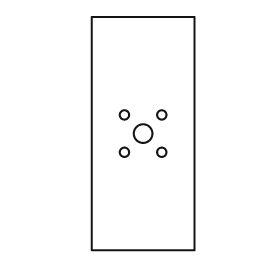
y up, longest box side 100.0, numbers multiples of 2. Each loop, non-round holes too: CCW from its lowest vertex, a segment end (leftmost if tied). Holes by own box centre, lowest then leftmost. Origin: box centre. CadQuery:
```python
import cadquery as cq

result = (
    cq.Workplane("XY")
    .moveTo(-22.0, -50.0)
    .lineTo(22.0, -50.0)
    .lineTo(22.0, 50.0)
    .lineTo(-22.0, 50.0)
    .close()
    .moveTo(-8.0, -8.0)
    .circle(2.0)
    .moveTo(8.0, -8.0)
    .circle(2.0)
    .moveTo(0.0, 0.0)
    .circle(4.0)
    .moveTo(-8.0, 8.0)
    .circle(2.0)
    .moveTo(8.0, 8.0)
    .circle(2.0)
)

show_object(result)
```